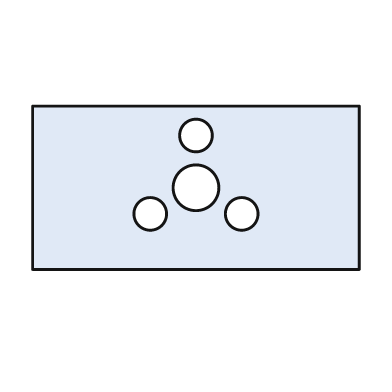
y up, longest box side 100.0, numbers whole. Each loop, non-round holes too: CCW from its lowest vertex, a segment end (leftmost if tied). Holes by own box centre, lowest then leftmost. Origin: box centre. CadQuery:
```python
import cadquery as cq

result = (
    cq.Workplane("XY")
    .moveTo(-50.0, -25.0)
    .lineTo(50.0, -25.0)
    .lineTo(50.0, 25.0)
    .lineTo(-50.0, 25.0)
    .close()
    .moveTo(-14.0, -8.0)
    .circle(5.0)
    .moveTo(14.0, -8.0)
    .circle(5.0)
    .moveTo(0.0, 0.0)
    .circle(7.0)
    .moveTo(0.0, 16.0)
    .circle(5.0)
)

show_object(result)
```